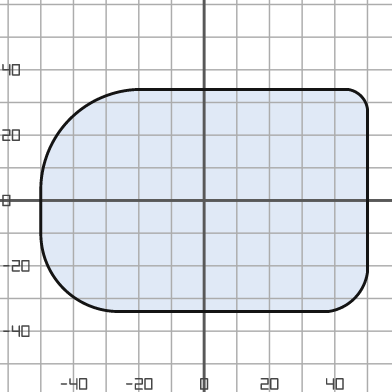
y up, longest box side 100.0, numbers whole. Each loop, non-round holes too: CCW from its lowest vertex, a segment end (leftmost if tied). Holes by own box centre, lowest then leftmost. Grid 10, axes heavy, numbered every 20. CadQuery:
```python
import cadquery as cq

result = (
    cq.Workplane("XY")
    .moveTo(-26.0, -34.0)
    .lineTo(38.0, -34.0)
    .threePointArc((46.0, -30.0), (50.0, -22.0))
    .lineTo(50.0, 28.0)
    .threePointArc((48.0, 32.0), (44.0, 34.0))
    .lineTo(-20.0, 34.0)
    .threePointArc((-41.0, 25.0), (-50.0, 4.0))
    .lineTo(-50.0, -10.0)
    .threePointArc((-43.0, -27.0), (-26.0, -34.0))
    .close()
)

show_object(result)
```